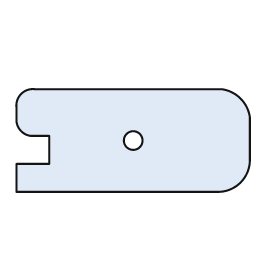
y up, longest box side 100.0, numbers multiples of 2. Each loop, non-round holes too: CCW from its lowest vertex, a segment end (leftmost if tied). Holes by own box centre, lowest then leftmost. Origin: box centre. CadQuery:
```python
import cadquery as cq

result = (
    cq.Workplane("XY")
    .moveTo(-50.0, -22.0)
    .lineTo(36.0, -22.0)
    .threePointArc((46.0, -18.0), (50.0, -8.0))
    .lineTo(50.0, 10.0)
    .threePointArc((46.0, 18.0), (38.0, 22.0))
    .lineTo(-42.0, 22.0)
    .threePointArc((-48.0, 20.0), (-50.0, 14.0))
    .lineTo(-50.0, 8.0)
    .threePointArc((-48.0, 4.0), (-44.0, 2.0))
    .lineTo(-36.0, 2.0)
    .lineTo(-36.0, -10.0)
    .lineTo(-50.0, -10.0)
    .close()
    .moveTo(0.0, 0.0)
    .circle(4.0)
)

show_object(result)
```